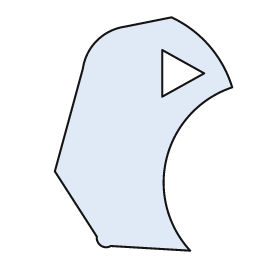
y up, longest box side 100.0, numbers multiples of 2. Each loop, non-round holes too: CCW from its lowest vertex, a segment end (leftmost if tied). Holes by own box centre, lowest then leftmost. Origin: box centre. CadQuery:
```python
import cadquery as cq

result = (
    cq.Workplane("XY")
    .moveTo(20.0, -50.0)
    .threePointArc((10.0, -10.0), (38.0, 20.0))
    .threePointArc((28.0, 38.0), (12.0, 50.0))
    .lineTo(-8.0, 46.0)
    .threePointArc((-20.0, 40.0), (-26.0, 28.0))
    .lineTo(-38.0, -16.0)
    .lineTo(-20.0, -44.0)
    .threePointArc((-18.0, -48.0), (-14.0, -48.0))
    .close()
    .moveTo(8.0, 16.0)
    .lineTo(26.0, 26.0)
    .lineTo(8.0, 36.0)
    .close()
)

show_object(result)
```